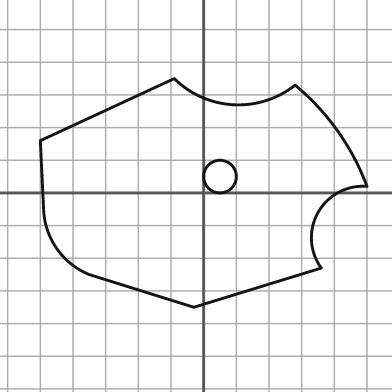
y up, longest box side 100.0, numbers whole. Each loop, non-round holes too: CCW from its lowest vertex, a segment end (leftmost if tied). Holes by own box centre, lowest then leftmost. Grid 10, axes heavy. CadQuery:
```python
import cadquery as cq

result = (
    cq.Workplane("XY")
    .moveTo(-3.0, -35.0)
    .lineTo(36.0, -23.0)
    .threePointArc((35.0, -6.0), (50.0, 2.0))
    .threePointArc((41.0, 19.0), (28.0, 33.0))
    .threePointArc((9.0, 27.0), (-9.0, 35.0))
    .lineTo(-50.0, 16.0)
    .lineTo(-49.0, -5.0)
    .threePointArc((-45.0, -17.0), (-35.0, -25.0))
    .close()
    .moveTo(5.0, 5.0)
    .circle(5.0)
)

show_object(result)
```